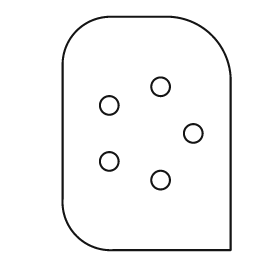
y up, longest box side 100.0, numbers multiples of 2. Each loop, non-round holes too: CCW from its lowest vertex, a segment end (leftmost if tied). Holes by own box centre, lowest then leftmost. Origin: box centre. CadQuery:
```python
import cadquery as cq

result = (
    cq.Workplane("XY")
    .moveTo(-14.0, -50.0)
    .lineTo(36.0, -50.0)
    .lineTo(36.0, 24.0)
    .threePointArc((28.0, 42.0), (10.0, 50.0))
    .lineTo(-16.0, 50.0)
    .threePointArc((-30.0, 44.0), (-36.0, 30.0))
    .lineTo(-36.0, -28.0)
    .threePointArc((-30.0, -44.0), (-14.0, -50.0))
    .close()
    .moveTo(6.0, -20.0)
    .circle(4.0)
    .moveTo(-16.0, -12.0)
    .circle(4.0)
    .moveTo(20.0, 0.0)
    .circle(4.0)
    .moveTo(-16.0, 12.0)
    .circle(4.0)
    .moveTo(6.0, 20.0)
    .circle(4.0)
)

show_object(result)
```